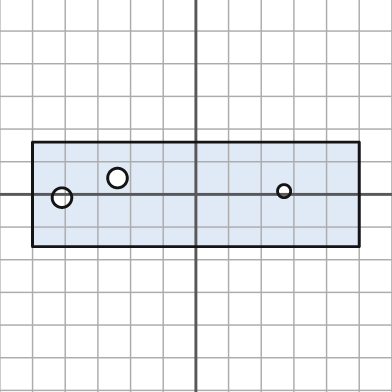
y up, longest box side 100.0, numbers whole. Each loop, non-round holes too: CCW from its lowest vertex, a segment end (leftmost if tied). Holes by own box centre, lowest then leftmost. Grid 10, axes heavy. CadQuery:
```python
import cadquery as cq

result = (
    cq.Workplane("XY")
    .moveTo(-50.0, -16.0)
    .lineTo(50.0, -16.0)
    .lineTo(50.0, 16.0)
    .lineTo(-50.0, 16.0)
    .close()
    .moveTo(-41.0, -1.0)
    .circle(3.0)
    .moveTo(27.0, 1.0)
    .circle(2.0)
    .moveTo(-24.0, 5.0)
    .circle(3.0)
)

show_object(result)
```